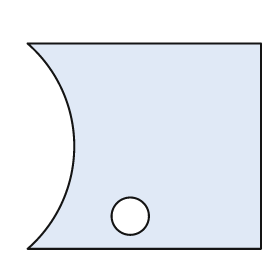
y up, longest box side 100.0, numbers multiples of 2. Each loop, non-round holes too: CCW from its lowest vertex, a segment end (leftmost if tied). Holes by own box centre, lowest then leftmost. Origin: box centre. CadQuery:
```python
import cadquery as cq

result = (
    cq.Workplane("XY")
    .moveTo(-50.0, -44.0)
    .lineTo(50.0, -44.0)
    .lineTo(50.0, 44.0)
    .lineTo(-50.0, 44.0)
    .threePointArc((-30.0, 0.0), (-50.0, -44.0))
    .close()
    .moveTo(-6.0, -30.0)
    .circle(8.0)
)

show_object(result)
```